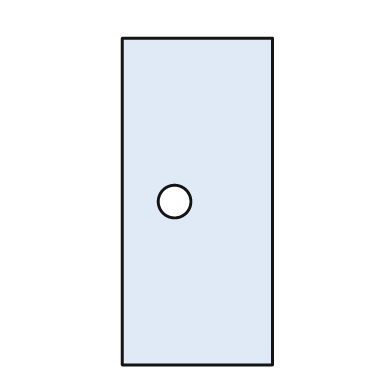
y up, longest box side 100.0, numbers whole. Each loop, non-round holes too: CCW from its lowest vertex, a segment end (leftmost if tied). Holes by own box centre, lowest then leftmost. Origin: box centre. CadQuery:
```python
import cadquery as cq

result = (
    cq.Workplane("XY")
    .moveTo(-23.0, -50.0)
    .lineTo(23.0, -50.0)
    .lineTo(23.0, 50.0)
    .lineTo(-23.0, 50.0)
    .close()
    .moveTo(-7.0, 0.0)
    .circle(5.0)
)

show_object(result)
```